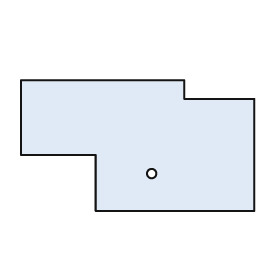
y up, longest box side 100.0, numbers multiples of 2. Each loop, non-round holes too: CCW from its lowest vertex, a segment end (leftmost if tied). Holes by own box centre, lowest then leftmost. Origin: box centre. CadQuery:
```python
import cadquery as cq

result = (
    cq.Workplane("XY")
    .moveTo(-18.0, -28.0)
    .lineTo(50.0, -28.0)
    .lineTo(50.0, 20.0)
    .lineTo(20.0, 20.0)
    .lineTo(20.0, 28.0)
    .lineTo(-50.0, 28.0)
    .lineTo(-50.0, -4.0)
    .lineTo(-18.0, -4.0)
    .close()
    .moveTo(6.0, -12.0)
    .circle(2.0)
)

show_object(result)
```